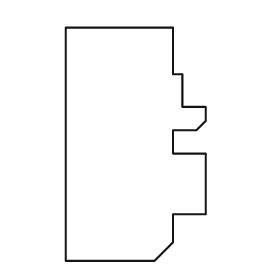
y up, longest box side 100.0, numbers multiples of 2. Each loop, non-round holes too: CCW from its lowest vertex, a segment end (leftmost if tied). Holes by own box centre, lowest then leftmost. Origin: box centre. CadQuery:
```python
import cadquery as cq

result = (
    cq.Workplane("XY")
    .moveTo(-30.0, -50.0)
    .lineTo(8.0, -50.0)
    .lineTo(16.0, -42.0)
    .lineTo(16.0, -30.0)
    .lineTo(30.0, -30.0)
    .lineTo(30.0, -4.0)
    .lineTo(16.0, -4.0)
    .lineTo(16.0, 6.0)
    .lineTo(26.0, 6.0)
    .lineTo(30.0, 10.0)
    .lineTo(30.0, 16.0)
    .lineTo(20.0, 16.0)
    .lineTo(20.0, 30.0)
    .lineTo(16.0, 30.0)
    .lineTo(16.0, 50.0)
    .lineTo(-30.0, 50.0)
    .close()
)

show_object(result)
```